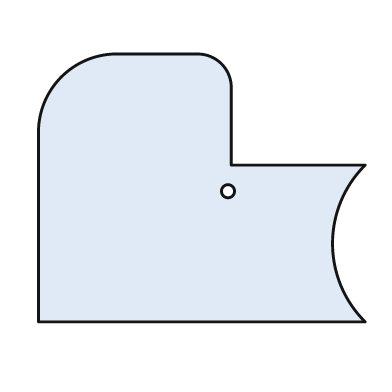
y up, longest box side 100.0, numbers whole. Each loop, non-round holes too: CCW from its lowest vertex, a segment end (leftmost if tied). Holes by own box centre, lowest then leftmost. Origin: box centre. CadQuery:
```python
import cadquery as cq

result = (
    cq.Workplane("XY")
    .moveTo(-50.0, -41.0)
    .lineTo(50.0, -41.0)
    .threePointArc((40.0, -17.0), (50.0, 7.0))
    .lineTo(9.0, 7.0)
    .lineTo(9.0, 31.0)
    .threePointArc((6.0, 38.0), (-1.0, 41.0))
    .lineTo(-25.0, 41.0)
    .threePointArc((-43.0, 34.0), (-50.0, 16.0))
    .close()
    .moveTo(8.0, -1.0)
    .circle(2.0)
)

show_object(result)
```